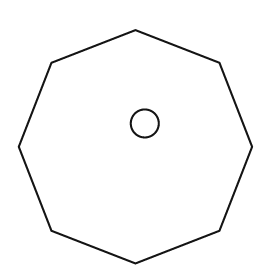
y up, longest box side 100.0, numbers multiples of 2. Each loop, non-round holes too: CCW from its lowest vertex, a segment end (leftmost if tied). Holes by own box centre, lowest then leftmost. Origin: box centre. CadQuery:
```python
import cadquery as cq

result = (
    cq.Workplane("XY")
    .moveTo(0.0, -50.0)
    .lineTo(36.0, -36.0)
    .lineTo(50.0, 0.0)
    .lineTo(36.0, 36.0)
    .lineTo(0.0, 50.0)
    .lineTo(-36.0, 36.0)
    .lineTo(-50.0, 0.0)
    .lineTo(-36.0, -36.0)
    .close()
    .moveTo(4.0, 10.0)
    .circle(6.0)
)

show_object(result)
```